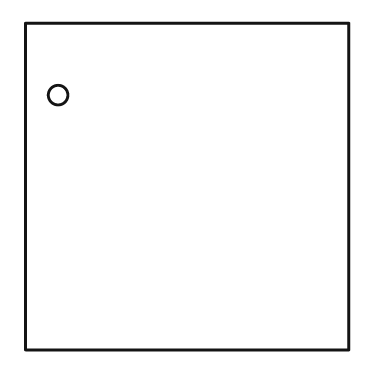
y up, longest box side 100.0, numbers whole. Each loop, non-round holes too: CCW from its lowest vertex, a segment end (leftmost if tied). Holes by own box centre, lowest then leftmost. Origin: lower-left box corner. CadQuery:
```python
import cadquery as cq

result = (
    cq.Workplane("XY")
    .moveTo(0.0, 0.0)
    .lineTo(99.0, 0.0)
    .lineTo(99.0, 100.0)
    .lineTo(0.0, 100.0)
    .close()
    .moveTo(10.0, 78.0)
    .circle(3.0)
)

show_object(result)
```